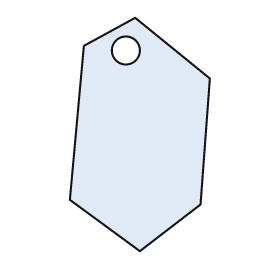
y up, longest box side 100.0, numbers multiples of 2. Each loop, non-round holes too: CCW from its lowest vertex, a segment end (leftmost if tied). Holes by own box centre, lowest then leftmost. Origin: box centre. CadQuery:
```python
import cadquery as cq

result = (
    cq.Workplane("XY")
    .moveTo(0.0, -50.0)
    .lineTo(26.0, -30.0)
    .lineTo(30.0, 24.0)
    .lineTo(-2.0, 50.0)
    .lineTo(-24.0, 38.0)
    .lineTo(-30.0, -28.0)
    .close()
    .moveTo(-6.0, 36.0)
    .circle(6.0)
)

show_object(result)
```